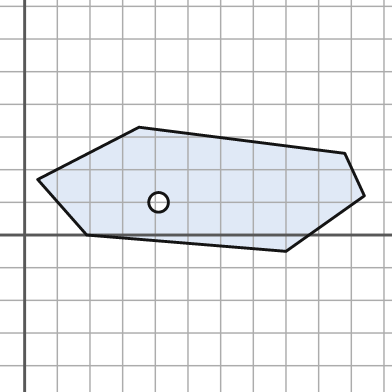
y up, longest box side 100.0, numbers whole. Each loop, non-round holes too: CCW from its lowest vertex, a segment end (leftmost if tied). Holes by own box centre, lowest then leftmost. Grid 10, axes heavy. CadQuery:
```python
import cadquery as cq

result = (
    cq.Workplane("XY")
    .moveTo(80.0, -5.0)
    .lineTo(104.0, 12.0)
    .lineTo(98.0, 25.0)
    .lineTo(35.0, 33.0)
    .lineTo(4.0, 17.0)
    .lineTo(19.0, 0.0)
    .close()
    .moveTo(41.0, 10.0)
    .circle(3.0)
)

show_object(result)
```